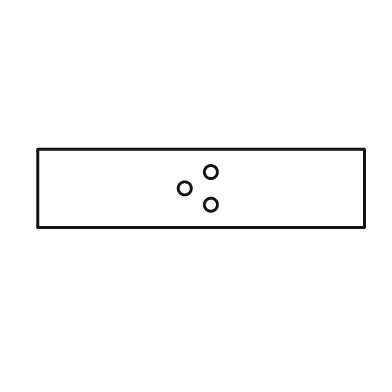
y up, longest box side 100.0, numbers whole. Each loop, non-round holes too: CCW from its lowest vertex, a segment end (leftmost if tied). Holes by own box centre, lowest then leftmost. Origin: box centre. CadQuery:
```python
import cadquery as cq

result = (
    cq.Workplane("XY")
    .moveTo(-50.0, -12.0)
    .lineTo(50.0, -12.0)
    .lineTo(50.0, 12.0)
    .lineTo(-50.0, 12.0)
    .close()
    .moveTo(3.0, -5.0)
    .circle(2.0)
    .moveTo(-5.0, 0.0)
    .circle(2.0)
    .moveTo(3.0, 5.0)
    .circle(2.0)
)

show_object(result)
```